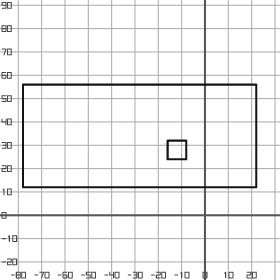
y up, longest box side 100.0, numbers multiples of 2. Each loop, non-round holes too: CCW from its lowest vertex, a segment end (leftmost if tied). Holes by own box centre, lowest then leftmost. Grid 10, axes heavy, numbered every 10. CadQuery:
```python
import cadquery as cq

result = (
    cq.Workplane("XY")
    .moveTo(-78.0, 12.0)
    .lineTo(22.0, 12.0)
    .lineTo(22.0, 56.0)
    .lineTo(-78.0, 56.0)
    .close()
    .moveTo(-16.0, 24.0)
    .lineTo(-8.0, 24.0)
    .lineTo(-8.0, 32.0)
    .lineTo(-16.0, 32.0)
    .close()
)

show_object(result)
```